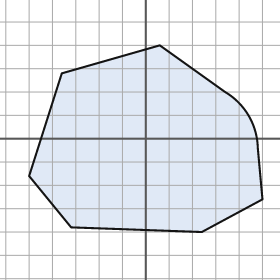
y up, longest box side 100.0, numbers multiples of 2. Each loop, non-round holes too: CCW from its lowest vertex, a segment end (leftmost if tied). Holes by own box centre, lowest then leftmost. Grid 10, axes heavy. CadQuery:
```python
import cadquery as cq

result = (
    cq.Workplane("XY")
    .moveTo(24.0, -40.0)
    .lineTo(50.0, -26.0)
    .lineTo(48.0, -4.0)
    .threePointArc((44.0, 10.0), (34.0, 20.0))
    .lineTo(6.0, 40.0)
    .lineTo(-36.0, 28.0)
    .lineTo(-50.0, -16.0)
    .lineTo(-32.0, -38.0)
    .close()
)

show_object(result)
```